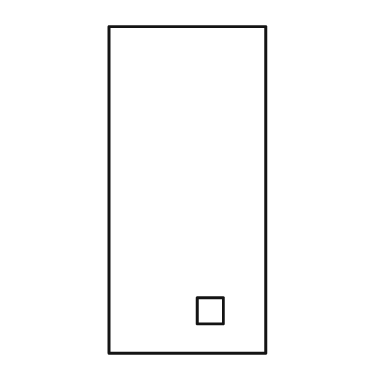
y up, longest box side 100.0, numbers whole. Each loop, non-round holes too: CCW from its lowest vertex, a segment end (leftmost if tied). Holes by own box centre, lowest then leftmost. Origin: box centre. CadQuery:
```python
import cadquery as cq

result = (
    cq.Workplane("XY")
    .moveTo(-24.0, -50.0)
    .lineTo(24.0, -50.0)
    .lineTo(24.0, 50.0)
    .lineTo(-24.0, 50.0)
    .close()
    .moveTo(3.0, -41.0)
    .lineTo(11.0, -41.0)
    .lineTo(11.0, -33.0)
    .lineTo(3.0, -33.0)
    .close()
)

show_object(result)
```